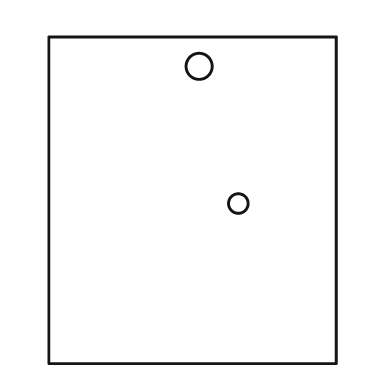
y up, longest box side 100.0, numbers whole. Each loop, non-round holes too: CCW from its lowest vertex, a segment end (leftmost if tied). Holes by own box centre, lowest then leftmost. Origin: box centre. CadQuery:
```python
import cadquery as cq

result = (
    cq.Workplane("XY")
    .moveTo(-44.0, -50.0)
    .lineTo(44.0, -50.0)
    .lineTo(44.0, 50.0)
    .lineTo(-44.0, 50.0)
    .close()
    .moveTo(14.0, -1.0)
    .circle(3.0)
    .moveTo(2.0, 41.0)
    .circle(4.0)
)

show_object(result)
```